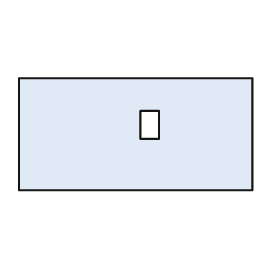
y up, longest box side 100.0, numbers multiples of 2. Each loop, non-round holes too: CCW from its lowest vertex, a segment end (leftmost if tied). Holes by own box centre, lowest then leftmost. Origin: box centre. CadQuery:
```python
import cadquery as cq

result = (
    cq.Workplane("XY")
    .moveTo(-50.0, -24.0)
    .lineTo(50.0, -24.0)
    .lineTo(50.0, 24.0)
    .lineTo(-50.0, 24.0)
    .close()
    .moveTo(2.0, -2.0)
    .lineTo(10.0, -2.0)
    .lineTo(10.0, 10.0)
    .lineTo(2.0, 10.0)
    .close()
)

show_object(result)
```